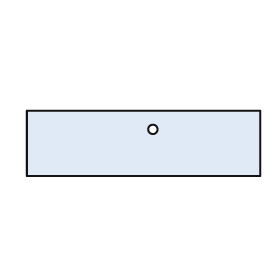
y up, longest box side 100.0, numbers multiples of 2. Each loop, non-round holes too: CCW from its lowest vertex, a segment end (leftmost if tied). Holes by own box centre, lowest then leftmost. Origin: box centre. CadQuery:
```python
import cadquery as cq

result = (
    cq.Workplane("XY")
    .moveTo(-50.0, -14.0)
    .lineTo(50.0, -14.0)
    .lineTo(50.0, 14.0)
    .lineTo(-50.0, 14.0)
    .close()
    .moveTo(4.0, 6.0)
    .circle(2.0)
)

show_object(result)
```